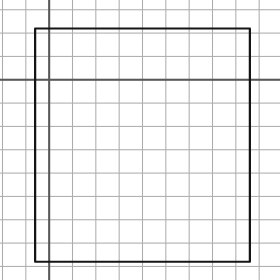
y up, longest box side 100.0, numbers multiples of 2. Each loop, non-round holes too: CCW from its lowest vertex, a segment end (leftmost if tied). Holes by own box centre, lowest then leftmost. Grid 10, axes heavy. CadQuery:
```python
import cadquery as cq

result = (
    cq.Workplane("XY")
    .moveTo(-6.0, -78.0)
    .lineTo(86.0, -78.0)
    .lineTo(86.0, 22.0)
    .lineTo(-6.0, 22.0)
    .close()
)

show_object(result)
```